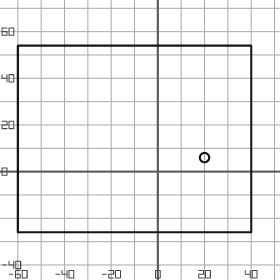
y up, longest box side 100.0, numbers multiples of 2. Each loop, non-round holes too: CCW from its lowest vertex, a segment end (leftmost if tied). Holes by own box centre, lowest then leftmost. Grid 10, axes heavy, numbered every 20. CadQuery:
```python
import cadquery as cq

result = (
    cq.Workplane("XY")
    .moveTo(-60.0, -26.0)
    .lineTo(40.0, -26.0)
    .lineTo(40.0, 54.0)
    .lineTo(-60.0, 54.0)
    .close()
    .moveTo(20.0, 6.0)
    .circle(2.0)
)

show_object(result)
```